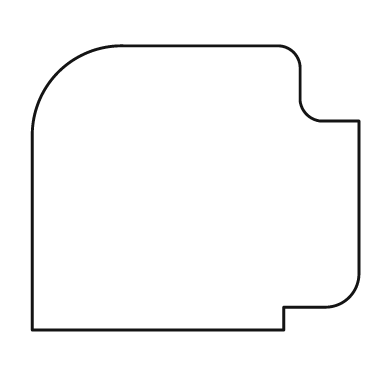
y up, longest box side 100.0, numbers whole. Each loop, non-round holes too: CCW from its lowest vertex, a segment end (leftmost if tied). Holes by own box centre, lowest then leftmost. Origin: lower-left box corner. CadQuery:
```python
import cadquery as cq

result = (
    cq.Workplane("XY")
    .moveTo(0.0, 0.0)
    .lineTo(77.0, 0.0)
    .lineTo(77.0, 7.0)
    .lineTo(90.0, 7.0)
    .threePointArc((97.0, 10.0), (100.0, 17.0))
    .lineTo(100.0, 64.0)
    .lineTo(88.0, 64.0)
    .threePointArc((84.0, 66.0), (82.0, 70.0))
    .lineTo(82.0, 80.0)
    .threePointArc((80.0, 85.0), (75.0, 87.0))
    .lineTo(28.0, 87.0)
    .threePointArc((8.0, 79.0), (0.0, 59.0))
    .close()
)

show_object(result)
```